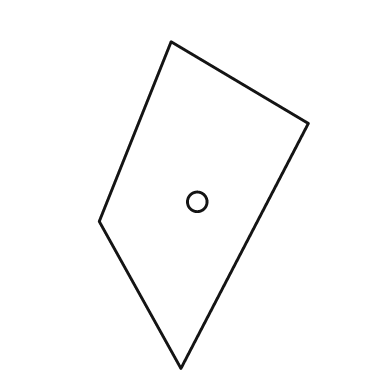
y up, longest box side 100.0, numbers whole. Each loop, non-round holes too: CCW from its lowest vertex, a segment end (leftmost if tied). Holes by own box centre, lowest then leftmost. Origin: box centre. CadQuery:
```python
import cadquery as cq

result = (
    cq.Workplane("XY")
    .moveTo(-7.0, -50.0)
    .lineTo(32.0, 25.0)
    .lineTo(-10.0, 50.0)
    .lineTo(-32.0, -5.0)
    .close()
    .moveTo(-2.0, 1.0)
    .circle(3.0)
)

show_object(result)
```